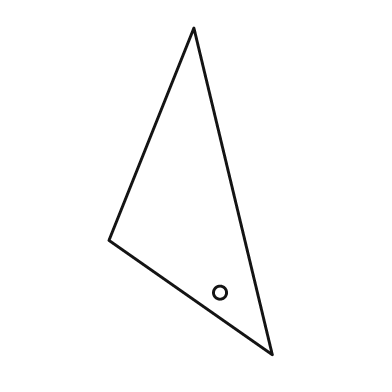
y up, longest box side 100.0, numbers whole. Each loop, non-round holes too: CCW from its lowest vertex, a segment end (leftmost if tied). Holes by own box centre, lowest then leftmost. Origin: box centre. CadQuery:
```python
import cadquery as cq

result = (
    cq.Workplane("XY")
    .moveTo(25.0, -50.0)
    .lineTo(1.0, 50.0)
    .lineTo(-25.0, -15.0)
    .close()
    .moveTo(9.0, -31.0)
    .circle(2.0)
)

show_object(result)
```